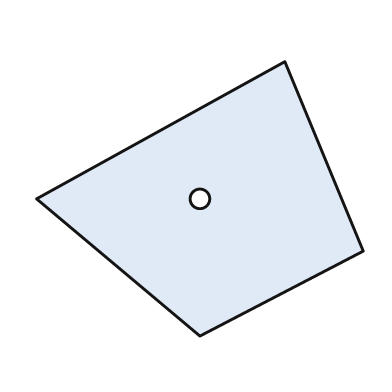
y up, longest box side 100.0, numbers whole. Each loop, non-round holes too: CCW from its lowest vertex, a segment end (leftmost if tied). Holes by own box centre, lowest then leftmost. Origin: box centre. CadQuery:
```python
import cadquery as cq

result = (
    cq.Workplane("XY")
    .moveTo(0.0, -42.0)
    .lineTo(50.0, -16.0)
    .lineTo(26.0, 42.0)
    .lineTo(-50.0, 0.0)
    .close()
    .moveTo(0.0, 0.0)
    .circle(3.0)
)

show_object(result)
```